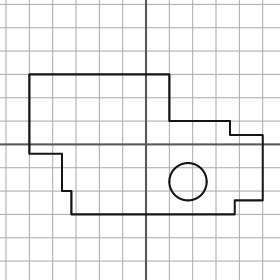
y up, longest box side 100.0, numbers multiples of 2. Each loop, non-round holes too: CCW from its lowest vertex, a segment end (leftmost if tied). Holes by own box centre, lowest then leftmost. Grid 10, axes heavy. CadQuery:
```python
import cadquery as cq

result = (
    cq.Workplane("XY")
    .moveTo(-32.0, -30.0)
    .lineTo(38.0, -30.0)
    .lineTo(38.0, -24.0)
    .lineTo(50.0, -24.0)
    .lineTo(50.0, 4.0)
    .lineTo(36.0, 4.0)
    .lineTo(36.0, 10.0)
    .lineTo(10.0, 10.0)
    .lineTo(10.0, 30.0)
    .lineTo(-50.0, 30.0)
    .lineTo(-50.0, -4.0)
    .lineTo(-36.0, -4.0)
    .lineTo(-36.0, -20.0)
    .lineTo(-32.0, -20.0)
    .close()
    .moveTo(18.0, -16.0)
    .circle(8.0)
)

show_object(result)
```